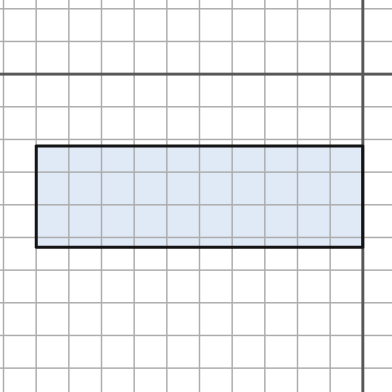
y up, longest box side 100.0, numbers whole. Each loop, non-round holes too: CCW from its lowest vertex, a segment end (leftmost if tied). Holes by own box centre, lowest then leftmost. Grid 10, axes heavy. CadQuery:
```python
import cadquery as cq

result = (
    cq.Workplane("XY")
    .moveTo(-100.0, -53.0)
    .lineTo(0.0, -53.0)
    .lineTo(0.0, -22.0)
    .lineTo(-100.0, -22.0)
    .close()
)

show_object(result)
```